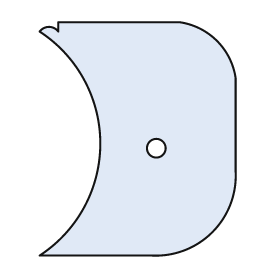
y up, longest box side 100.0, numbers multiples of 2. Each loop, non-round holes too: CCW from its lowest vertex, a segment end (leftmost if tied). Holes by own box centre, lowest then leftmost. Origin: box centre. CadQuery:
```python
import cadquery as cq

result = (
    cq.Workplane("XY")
    .moveTo(-42.0, -50.0)
    .lineTo(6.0, -50.0)
    .threePointArc((32.0, -40.0), (42.0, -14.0))
    .lineTo(42.0, 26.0)
    .threePointArc((34.0, 42.0), (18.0, 50.0))
    .lineTo(-34.0, 50.0)
    .lineTo(-34.0, 46.0)
    .threePointArc((-38.0, 48.0), (-42.0, 46.0))
    .threePointArc((-16.0, -2.0), (-42.0, -50.0))
    .close()
    .moveTo(8.0, -4.0)
    .circle(4.0)
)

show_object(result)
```